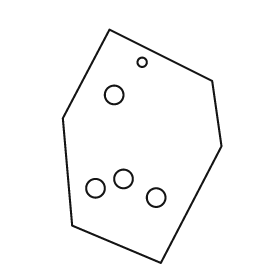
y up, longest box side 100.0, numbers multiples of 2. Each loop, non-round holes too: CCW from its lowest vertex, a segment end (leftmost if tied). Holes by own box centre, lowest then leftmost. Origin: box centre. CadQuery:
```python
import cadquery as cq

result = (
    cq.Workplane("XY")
    .moveTo(8.0, -50.0)
    .lineTo(34.0, 0.0)
    .lineTo(30.0, 28.0)
    .lineTo(-14.0, 50.0)
    .lineTo(-34.0, 12.0)
    .lineTo(-30.0, -34.0)
    .close()
    .moveTo(6.0, -22.0)
    .circle(4.0)
    .moveTo(-20.0, -18.0)
    .circle(4.0)
    .moveTo(-8.0, -14.0)
    .circle(4.0)
    .moveTo(-12.0, 22.0)
    .circle(4.0)
    .moveTo(0.0, 36.0)
    .circle(2.0)
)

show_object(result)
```